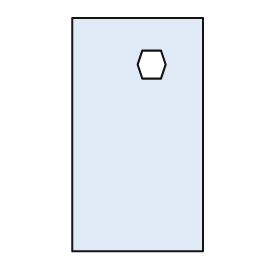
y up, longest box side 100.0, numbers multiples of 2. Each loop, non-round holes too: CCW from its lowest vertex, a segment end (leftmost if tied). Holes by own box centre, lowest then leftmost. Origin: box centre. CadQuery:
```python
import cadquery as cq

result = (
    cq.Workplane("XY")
    .moveTo(-28.0, -50.0)
    .lineTo(28.0, -50.0)
    .lineTo(28.0, 50.0)
    .lineTo(-28.0, 50.0)
    .close()
    .moveTo(2.0, 24.0)
    .lineTo(10.0, 24.0)
    .lineTo(12.0, 30.0)
    .lineTo(10.0, 36.0)
    .lineTo(2.0, 36.0)
    .lineTo(0.0, 30.0)
    .close()
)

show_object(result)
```